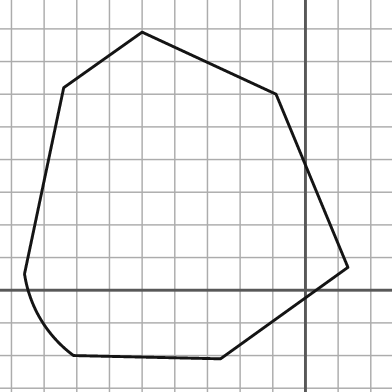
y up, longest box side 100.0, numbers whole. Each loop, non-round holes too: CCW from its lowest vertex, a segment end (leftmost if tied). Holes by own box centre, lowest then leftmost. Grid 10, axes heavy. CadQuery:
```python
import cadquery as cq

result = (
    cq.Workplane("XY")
    .moveTo(-26.0, -21.0)
    .lineTo(13.0, 7.0)
    .lineTo(-9.0, 60.0)
    .lineTo(-50.0, 79.0)
    .lineTo(-74.0, 62.0)
    .lineTo(-86.0, 5.0)
    .threePointArc((-81.0, -9.0), (-71.0, -20.0))
    .close()
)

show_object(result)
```